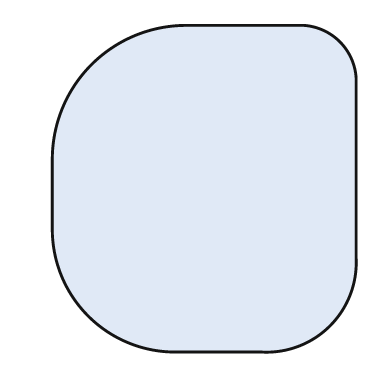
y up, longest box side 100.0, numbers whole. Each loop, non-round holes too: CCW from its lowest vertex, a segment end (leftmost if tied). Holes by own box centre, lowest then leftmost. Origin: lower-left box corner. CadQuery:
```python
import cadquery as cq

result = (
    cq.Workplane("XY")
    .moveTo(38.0, 0.0)
    .lineTo(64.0, 0.0)
    .threePointArc((85.0, 8.0), (93.0, 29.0))
    .lineTo(93.0, 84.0)
    .threePointArc((88.0, 95.0), (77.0, 100.0))
    .lineTo(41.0, 100.0)
    .threePointArc((12.0, 88.0), (0.0, 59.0))
    .lineTo(0.0, 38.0)
    .threePointArc((11.0, 11.0), (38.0, 0.0))
    .close()
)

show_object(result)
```